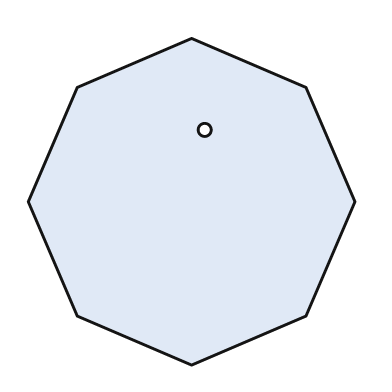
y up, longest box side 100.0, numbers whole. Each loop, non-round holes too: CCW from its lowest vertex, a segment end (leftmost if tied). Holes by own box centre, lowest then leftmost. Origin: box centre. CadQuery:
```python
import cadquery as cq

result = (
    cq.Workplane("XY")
    .moveTo(0.0, -50.0)
    .lineTo(35.0, -35.0)
    .lineTo(50.0, 0.0)
    .lineTo(35.0, 35.0)
    .lineTo(0.0, 50.0)
    .lineTo(-35.0, 35.0)
    .lineTo(-50.0, 0.0)
    .lineTo(-35.0, -35.0)
    .close()
    .moveTo(4.0, 22.0)
    .circle(2.0)
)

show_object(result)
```